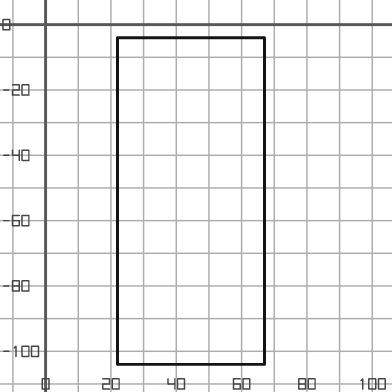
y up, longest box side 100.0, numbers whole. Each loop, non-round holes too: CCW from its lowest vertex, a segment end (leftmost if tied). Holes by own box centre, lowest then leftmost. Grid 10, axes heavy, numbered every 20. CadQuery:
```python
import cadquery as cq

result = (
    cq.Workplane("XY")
    .moveTo(22.0, -104.0)
    .lineTo(67.0, -104.0)
    .lineTo(67.0, -4.0)
    .lineTo(22.0, -4.0)
    .close()
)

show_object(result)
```